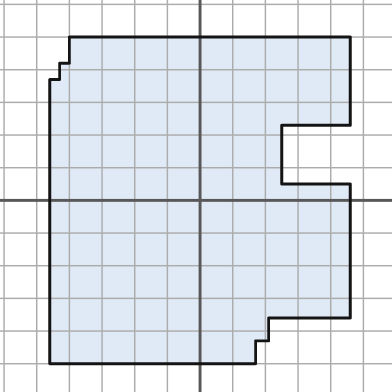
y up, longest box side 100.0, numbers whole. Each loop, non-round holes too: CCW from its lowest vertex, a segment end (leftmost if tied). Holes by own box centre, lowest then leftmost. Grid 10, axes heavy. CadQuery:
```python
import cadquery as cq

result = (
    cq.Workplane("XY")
    .moveTo(-46.0, -50.0)
    .lineTo(17.0, -50.0)
    .lineTo(17.0, -43.0)
    .lineTo(21.0, -43.0)
    .lineTo(21.0, -36.0)
    .lineTo(46.0, -36.0)
    .lineTo(46.0, 5.0)
    .lineTo(25.0, 5.0)
    .lineTo(25.0, 23.0)
    .lineTo(46.0, 23.0)
    .lineTo(46.0, 50.0)
    .lineTo(-40.0, 50.0)
    .lineTo(-40.0, 42.0)
    .lineTo(-43.0, 42.0)
    .lineTo(-43.0, 37.0)
    .lineTo(-46.0, 37.0)
    .close()
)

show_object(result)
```